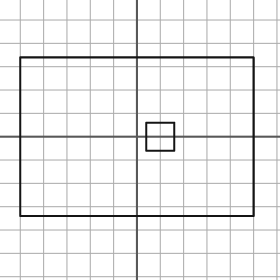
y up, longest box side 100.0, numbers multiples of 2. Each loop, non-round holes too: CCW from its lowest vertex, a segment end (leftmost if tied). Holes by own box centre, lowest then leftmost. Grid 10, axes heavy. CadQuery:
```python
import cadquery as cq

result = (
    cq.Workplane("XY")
    .moveTo(-50.0, -34.0)
    .lineTo(50.0, -34.0)
    .lineTo(50.0, 34.0)
    .lineTo(-50.0, 34.0)
    .close()
    .moveTo(4.0, -6.0)
    .lineTo(16.0, -6.0)
    .lineTo(16.0, 6.0)
    .lineTo(4.0, 6.0)
    .close()
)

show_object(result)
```